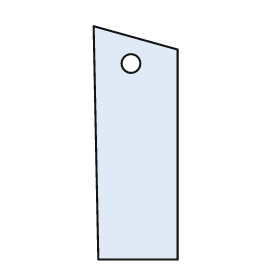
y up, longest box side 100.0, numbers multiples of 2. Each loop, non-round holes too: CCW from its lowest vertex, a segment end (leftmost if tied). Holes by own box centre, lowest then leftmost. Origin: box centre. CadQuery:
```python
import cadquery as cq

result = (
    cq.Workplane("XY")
    .moveTo(-16.0, -50.0)
    .lineTo(18.0, -50.0)
    .lineTo(18.0, 40.0)
    .lineTo(-18.0, 50.0)
    .close()
    .moveTo(-2.0, 34.0)
    .circle(4.0)
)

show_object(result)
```